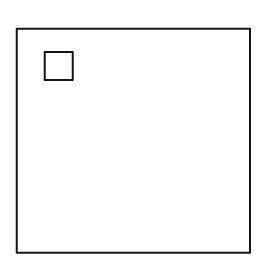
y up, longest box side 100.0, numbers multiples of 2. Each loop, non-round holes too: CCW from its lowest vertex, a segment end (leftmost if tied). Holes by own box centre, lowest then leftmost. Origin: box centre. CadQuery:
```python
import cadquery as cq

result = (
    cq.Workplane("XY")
    .moveTo(-50.0, -48.0)
    .lineTo(50.0, -48.0)
    .lineTo(50.0, 48.0)
    .lineTo(-50.0, 48.0)
    .close()
    .moveTo(-38.0, 26.0)
    .lineTo(-26.0, 26.0)
    .lineTo(-26.0, 38.0)
    .lineTo(-38.0, 38.0)
    .close()
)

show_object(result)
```